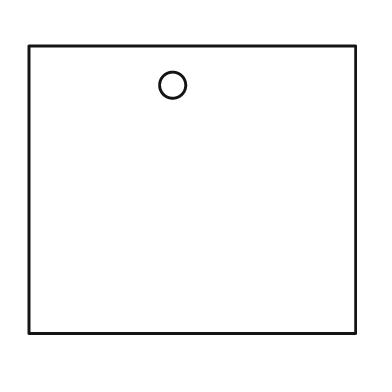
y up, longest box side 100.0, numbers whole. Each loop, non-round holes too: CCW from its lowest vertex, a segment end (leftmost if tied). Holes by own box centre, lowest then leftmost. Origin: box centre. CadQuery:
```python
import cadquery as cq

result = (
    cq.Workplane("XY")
    .moveTo(-50.0, -44.0)
    .lineTo(50.0, -44.0)
    .lineTo(50.0, 44.0)
    .lineTo(-50.0, 44.0)
    .close()
    .moveTo(-6.0, 32.0)
    .circle(4.0)
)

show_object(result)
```